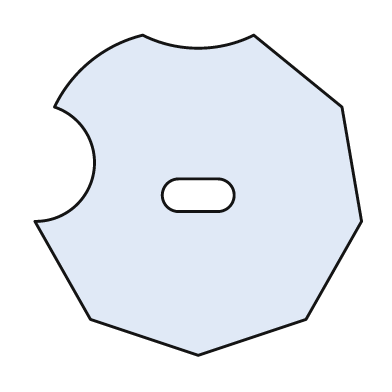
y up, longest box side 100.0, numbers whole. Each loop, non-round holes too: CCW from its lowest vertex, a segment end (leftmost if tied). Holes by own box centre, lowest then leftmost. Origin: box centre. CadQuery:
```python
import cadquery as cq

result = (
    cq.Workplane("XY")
    .moveTo(0.0, -49.0)
    .lineTo(33.0, -38.0)
    .lineTo(50.0, -8.0)
    .lineTo(44.0, 27.0)
    .lineTo(17.0, 49.0)
    .threePointArc((0.0, 45.0), (-17.0, 49.0))
    .threePointArc((-33.0, 41.0), (-44.0, 27.0))
    .threePointArc((-32.0, 7.0), (-50.0, -8.0))
    .lineTo(-33.0, -38.0)
    .close()
    .moveTo(-6.0, -5.0)
    .lineTo(6.0, -5.0)
    .threePointArc((11.0, 0.0), (6.0, 5.0))
    .lineTo(-6.0, 5.0)
    .threePointArc((-11.0, 0.0), (-6.0, -5.0))
    .close()
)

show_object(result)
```